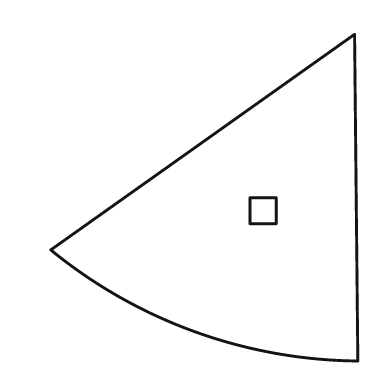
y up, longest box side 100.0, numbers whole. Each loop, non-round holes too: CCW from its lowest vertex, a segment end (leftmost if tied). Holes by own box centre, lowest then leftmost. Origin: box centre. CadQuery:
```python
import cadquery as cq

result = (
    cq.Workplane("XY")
    .moveTo(47.0, -50.0)
    .lineTo(46.0, 50.0)
    .lineTo(-47.0, -16.0)
    .threePointArc((-3.0, -41.0), (47.0, -50.0))
    .close()
    .moveTo(14.0, -8.0)
    .lineTo(22.0, -8.0)
    .lineTo(22.0, 0.0)
    .lineTo(14.0, 0.0)
    .close()
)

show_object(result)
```